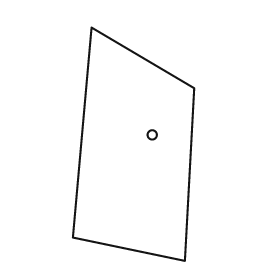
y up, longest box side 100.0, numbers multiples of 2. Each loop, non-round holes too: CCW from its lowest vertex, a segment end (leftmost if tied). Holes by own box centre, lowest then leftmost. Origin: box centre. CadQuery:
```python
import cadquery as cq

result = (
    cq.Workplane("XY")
    .moveTo(22.0, -50.0)
    .lineTo(26.0, 24.0)
    .lineTo(-18.0, 50.0)
    .lineTo(-26.0, -40.0)
    .close()
    .moveTo(8.0, 4.0)
    .circle(2.0)
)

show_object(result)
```